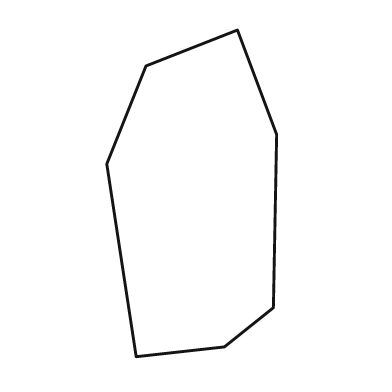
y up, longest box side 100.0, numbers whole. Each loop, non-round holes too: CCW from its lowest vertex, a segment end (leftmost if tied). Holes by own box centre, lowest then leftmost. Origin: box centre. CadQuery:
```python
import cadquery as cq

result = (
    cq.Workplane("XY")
    .moveTo(-17.0, -50.0)
    .lineTo(10.0, -47.0)
    .lineTo(25.0, -35.0)
    .lineTo(26.0, 18.0)
    .lineTo(14.0, 50.0)
    .lineTo(-14.0, 39.0)
    .lineTo(-26.0, 9.0)
    .close()
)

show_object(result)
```